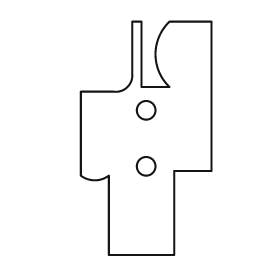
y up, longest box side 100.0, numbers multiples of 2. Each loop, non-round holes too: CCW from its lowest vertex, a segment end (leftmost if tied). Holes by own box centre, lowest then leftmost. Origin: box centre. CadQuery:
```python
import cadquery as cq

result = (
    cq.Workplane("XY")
    .moveTo(-16.0, -50.0)
    .lineTo(12.0, -50.0)
    .lineTo(12.0, -14.0)
    .lineTo(28.0, -14.0)
    .lineTo(28.0, 50.0)
    .lineTo(10.0, 50.0)
    .threePointArc((4.0, 36.0), (10.0, 22.0))
    .lineTo(-2.0, 22.0)
    .lineTo(-2.0, 50.0)
    .lineTo(-6.0, 50.0)
    .lineTo(-6.0, 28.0)
    .threePointArc((-8.0, 22.0), (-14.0, 20.0))
    .lineTo(-28.0, 20.0)
    .lineTo(-28.0, -16.0)
    .threePointArc((-22.0, -18.0), (-16.0, -16.0))
    .close()
    .moveTo(0.0, -12.0)
    .circle(4.0)
    .moveTo(0.0, 12.0)
    .circle(4.0)
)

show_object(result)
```